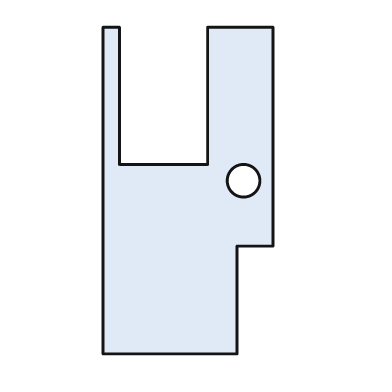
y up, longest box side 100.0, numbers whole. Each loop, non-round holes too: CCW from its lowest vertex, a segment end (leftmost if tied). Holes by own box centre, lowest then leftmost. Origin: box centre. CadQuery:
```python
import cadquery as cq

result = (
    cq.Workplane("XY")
    .moveTo(-26.0, -50.0)
    .lineTo(15.0, -50.0)
    .lineTo(15.0, -17.0)
    .lineTo(26.0, -17.0)
    .lineTo(26.0, 50.0)
    .lineTo(6.0, 50.0)
    .lineTo(6.0, 8.0)
    .lineTo(-21.0, 8.0)
    .lineTo(-21.0, 50.0)
    .lineTo(-26.0, 50.0)
    .close()
    .moveTo(17.0, 3.0)
    .circle(5.0)
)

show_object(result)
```